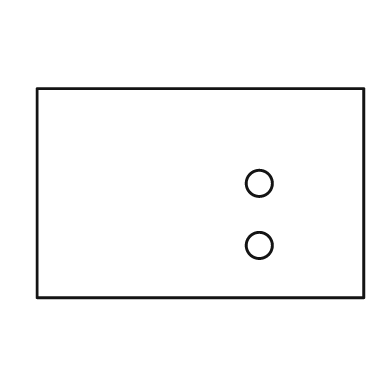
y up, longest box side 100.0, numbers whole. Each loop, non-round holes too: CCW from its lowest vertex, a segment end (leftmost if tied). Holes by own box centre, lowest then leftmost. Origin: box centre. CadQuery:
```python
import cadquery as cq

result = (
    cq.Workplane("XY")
    .moveTo(-50.0, -32.0)
    .lineTo(50.0, -32.0)
    .lineTo(50.0, 32.0)
    .lineTo(-50.0, 32.0)
    .close()
    .moveTo(18.0, -16.0)
    .circle(4.0)
    .moveTo(18.0, 3.0)
    .circle(4.0)
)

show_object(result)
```